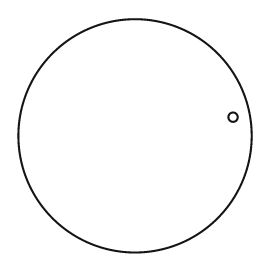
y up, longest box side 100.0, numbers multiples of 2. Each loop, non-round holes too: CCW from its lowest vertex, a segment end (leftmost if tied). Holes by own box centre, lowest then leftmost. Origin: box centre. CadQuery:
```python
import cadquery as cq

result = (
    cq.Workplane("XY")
    .moveTo(0.0, 0.0)
    .circle(50.0)
    .moveTo(42.0, 8.0)
    .circle(2.0)
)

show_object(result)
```